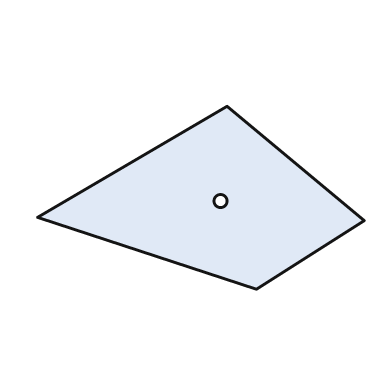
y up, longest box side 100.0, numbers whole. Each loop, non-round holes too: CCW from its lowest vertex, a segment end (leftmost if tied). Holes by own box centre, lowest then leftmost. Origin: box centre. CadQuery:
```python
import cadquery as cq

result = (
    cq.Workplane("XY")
    .moveTo(17.0, -28.0)
    .lineTo(50.0, -7.0)
    .lineTo(8.0, 28.0)
    .lineTo(-50.0, -6.0)
    .close()
    .moveTo(6.0, -1.0)
    .circle(2.0)
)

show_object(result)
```